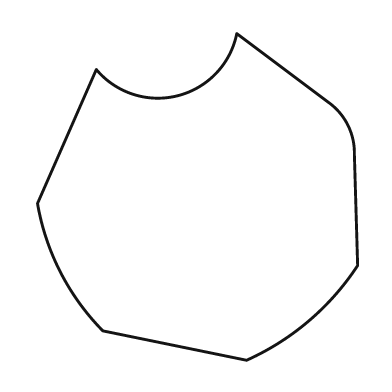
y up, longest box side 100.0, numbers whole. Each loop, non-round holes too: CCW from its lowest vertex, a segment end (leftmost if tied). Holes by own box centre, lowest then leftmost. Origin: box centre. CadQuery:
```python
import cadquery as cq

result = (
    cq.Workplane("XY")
    .moveTo(15.0, -50.0)
    .threePointArc((34.0, -38.0), (49.0, -21.0))
    .lineTo(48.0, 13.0)
    .threePointArc((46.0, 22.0), (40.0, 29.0))
    .lineTo(12.0, 50.0)
    .threePointArc((-6.0, 31.0), (-31.0, 39.0))
    .lineTo(-49.0, -2.0)
    .threePointArc((-42.0, -23.0), (-29.0, -41.0))
    .close()
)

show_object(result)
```